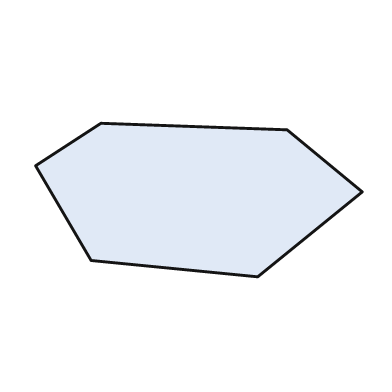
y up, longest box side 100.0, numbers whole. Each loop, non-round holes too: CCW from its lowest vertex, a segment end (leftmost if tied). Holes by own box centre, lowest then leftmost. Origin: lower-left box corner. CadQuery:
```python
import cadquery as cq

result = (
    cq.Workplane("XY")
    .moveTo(68.0, 0.0)
    .lineTo(100.0, 26.0)
    .lineTo(77.0, 45.0)
    .lineTo(20.0, 47.0)
    .lineTo(0.0, 34.0)
    .lineTo(17.0, 5.0)
    .close()
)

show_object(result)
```